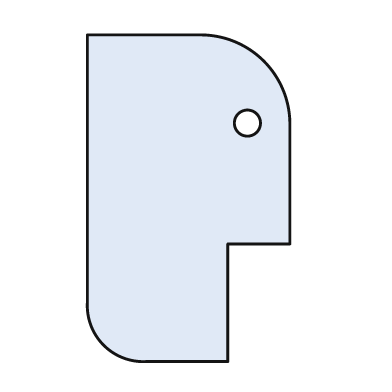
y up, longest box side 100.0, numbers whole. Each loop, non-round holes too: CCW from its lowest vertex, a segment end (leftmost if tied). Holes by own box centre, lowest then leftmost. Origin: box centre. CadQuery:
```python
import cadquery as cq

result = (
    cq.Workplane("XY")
    .moveTo(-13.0, -50.0)
    .lineTo(12.0, -50.0)
    .lineTo(12.0, -14.0)
    .lineTo(31.0, -14.0)
    .lineTo(31.0, 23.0)
    .threePointArc((23.0, 42.0), (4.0, 50.0))
    .lineTo(-31.0, 50.0)
    .lineTo(-31.0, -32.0)
    .threePointArc((-26.0, -45.0), (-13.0, -50.0))
    .close()
    .moveTo(18.0, 23.0)
    .circle(4.0)
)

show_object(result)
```